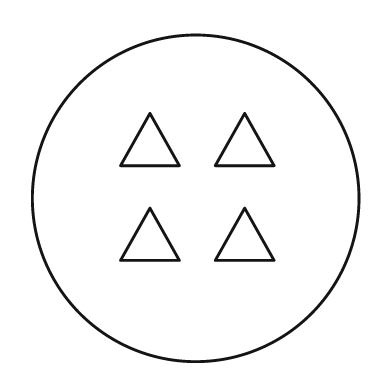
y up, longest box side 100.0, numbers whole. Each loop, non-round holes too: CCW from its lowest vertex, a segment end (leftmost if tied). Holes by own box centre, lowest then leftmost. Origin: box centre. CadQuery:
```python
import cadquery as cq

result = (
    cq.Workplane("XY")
    .moveTo(0.0, 0.0)
    .circle(50.0)
    .moveTo(-23.0, -19.0)
    .lineTo(-5.0, -19.0)
    .lineTo(-14.0, -3.0)
    .close()
    .moveTo(6.0, -19.0)
    .lineTo(24.0, -19.0)
    .lineTo(15.0, -3.0)
    .close()
    .moveTo(-23.0, 10.0)
    .lineTo(-5.0, 10.0)
    .lineTo(-14.0, 26.0)
    .close()
    .moveTo(6.0, 10.0)
    .lineTo(24.0, 10.0)
    .lineTo(15.0, 26.0)
    .close()
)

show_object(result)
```